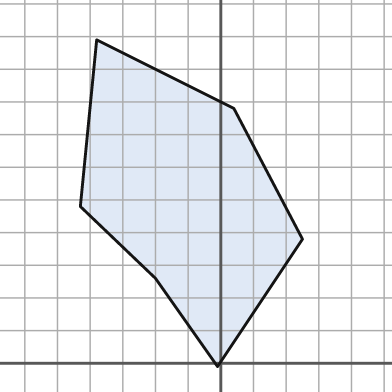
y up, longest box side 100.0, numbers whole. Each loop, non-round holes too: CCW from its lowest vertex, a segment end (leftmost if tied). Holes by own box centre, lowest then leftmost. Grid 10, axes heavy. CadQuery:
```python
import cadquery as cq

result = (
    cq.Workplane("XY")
    .moveTo(-1.0, -1.0)
    .lineTo(25.0, 38.0)
    .lineTo(4.0, 78.0)
    .lineTo(-38.0, 99.0)
    .lineTo(-43.0, 48.0)
    .lineTo(-20.0, 26.0)
    .close()
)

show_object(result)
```